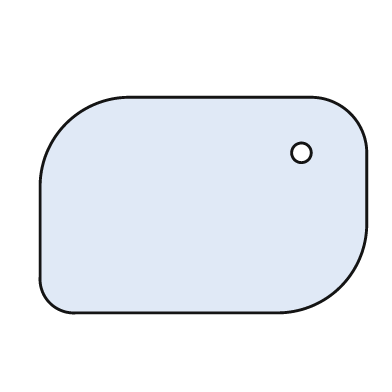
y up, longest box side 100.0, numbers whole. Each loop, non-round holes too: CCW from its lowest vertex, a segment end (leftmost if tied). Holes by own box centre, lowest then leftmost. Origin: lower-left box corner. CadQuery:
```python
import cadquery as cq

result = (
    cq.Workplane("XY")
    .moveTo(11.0, 0.0)
    .lineTo(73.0, 0.0)
    .threePointArc((92.0, 8.0), (100.0, 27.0))
    .lineTo(100.0, 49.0)
    .threePointArc((95.0, 61.0), (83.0, 66.0))
    .lineTo(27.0, 66.0)
    .threePointArc((8.0, 58.0), (0.0, 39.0))
    .lineTo(0.0, 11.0)
    .threePointArc((3.0, 3.0), (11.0, 0.0))
    .close()
    .moveTo(80.0, 49.0)
    .circle(3.0)
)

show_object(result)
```